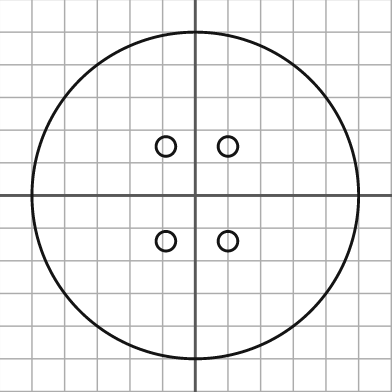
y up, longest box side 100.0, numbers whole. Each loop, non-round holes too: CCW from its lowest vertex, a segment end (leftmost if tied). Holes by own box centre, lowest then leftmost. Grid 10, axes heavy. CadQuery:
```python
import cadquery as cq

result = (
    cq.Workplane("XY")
    .moveTo(0.0, 0.0)
    .circle(50.0)
    .moveTo(-9.0, -14.0)
    .circle(3.0)
    .moveTo(10.0, -14.0)
    .circle(3.0)
    .moveTo(-9.0, 15.0)
    .circle(3.0)
    .moveTo(10.0, 15.0)
    .circle(3.0)
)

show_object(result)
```